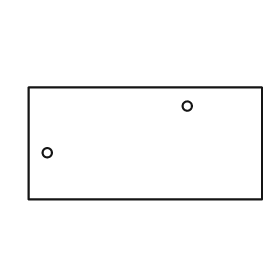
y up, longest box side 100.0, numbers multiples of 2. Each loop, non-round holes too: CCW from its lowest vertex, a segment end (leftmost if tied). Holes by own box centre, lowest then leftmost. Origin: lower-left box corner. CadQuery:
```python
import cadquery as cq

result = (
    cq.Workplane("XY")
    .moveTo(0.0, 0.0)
    .lineTo(100.0, 0.0)
    .lineTo(100.0, 48.0)
    .lineTo(0.0, 48.0)
    .close()
    .moveTo(8.0, 20.0)
    .circle(2.0)
    .moveTo(68.0, 40.0)
    .circle(2.0)
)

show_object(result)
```